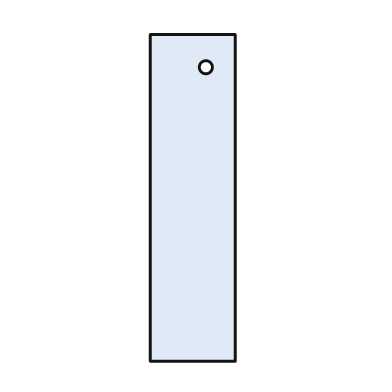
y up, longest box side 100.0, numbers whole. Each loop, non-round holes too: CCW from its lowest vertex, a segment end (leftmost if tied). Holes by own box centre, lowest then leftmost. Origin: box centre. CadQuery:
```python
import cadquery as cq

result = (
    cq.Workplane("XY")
    .moveTo(-13.0, -50.0)
    .lineTo(13.0, -50.0)
    .lineTo(13.0, 50.0)
    .lineTo(-13.0, 50.0)
    .close()
    .moveTo(4.0, 40.0)
    .circle(2.0)
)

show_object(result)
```